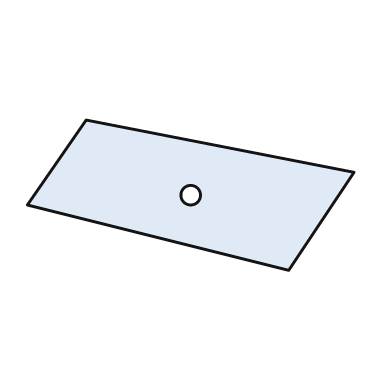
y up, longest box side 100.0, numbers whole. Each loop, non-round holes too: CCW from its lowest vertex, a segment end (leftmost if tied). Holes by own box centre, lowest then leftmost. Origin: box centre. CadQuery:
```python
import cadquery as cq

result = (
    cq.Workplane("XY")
    .moveTo(30.0, -23.0)
    .lineTo(50.0, 7.0)
    .lineTo(-32.0, 23.0)
    .lineTo(-50.0, -3.0)
    .close()
    .moveTo(0.0, 0.0)
    .circle(3.0)
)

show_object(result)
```